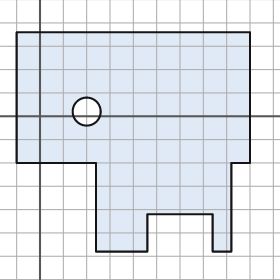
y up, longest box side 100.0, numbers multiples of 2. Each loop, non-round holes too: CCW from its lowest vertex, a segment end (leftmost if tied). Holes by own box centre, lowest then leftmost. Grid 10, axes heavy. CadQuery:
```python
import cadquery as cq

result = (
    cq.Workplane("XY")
    .moveTo(24.0, -58.0)
    .lineTo(46.0, -58.0)
    .lineTo(46.0, -42.0)
    .lineTo(74.0, -42.0)
    .lineTo(74.0, -58.0)
    .lineTo(82.0, -58.0)
    .lineTo(82.0, -20.0)
    .lineTo(90.0, -20.0)
    .lineTo(90.0, 36.0)
    .lineTo(-10.0, 36.0)
    .lineTo(-10.0, -20.0)
    .lineTo(24.0, -20.0)
    .close()
    .moveTo(20.0, 2.0)
    .circle(6.0)
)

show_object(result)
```